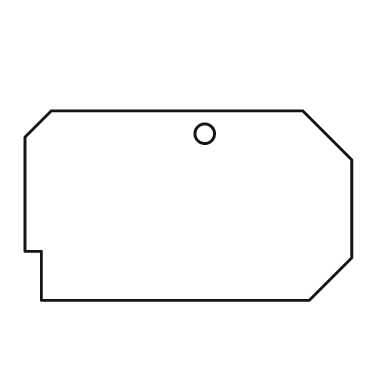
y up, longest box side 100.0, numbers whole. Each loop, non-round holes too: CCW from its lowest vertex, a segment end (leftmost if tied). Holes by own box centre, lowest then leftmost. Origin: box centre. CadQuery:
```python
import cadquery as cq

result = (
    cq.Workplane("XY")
    .moveTo(-45.0, -29.0)
    .lineTo(37.0, -29.0)
    .lineTo(50.0, -16.0)
    .lineTo(50.0, 14.0)
    .lineTo(35.0, 29.0)
    .lineTo(-42.0, 29.0)
    .lineTo(-50.0, 21.0)
    .lineTo(-50.0, -14.0)
    .lineTo(-45.0, -14.0)
    .close()
    .moveTo(5.0, 22.0)
    .circle(3.0)
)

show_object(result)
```